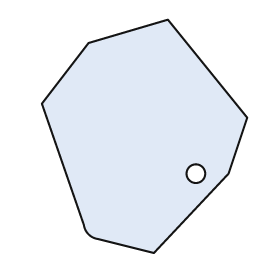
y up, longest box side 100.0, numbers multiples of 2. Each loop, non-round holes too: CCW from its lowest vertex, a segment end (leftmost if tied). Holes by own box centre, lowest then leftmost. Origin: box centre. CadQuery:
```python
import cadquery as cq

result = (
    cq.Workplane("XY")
    .moveTo(4.0, -50.0)
    .lineTo(36.0, -16.0)
    .lineTo(44.0, 8.0)
    .lineTo(10.0, 50.0)
    .lineTo(-24.0, 40.0)
    .lineTo(-44.0, 14.0)
    .lineTo(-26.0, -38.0)
    .threePointArc((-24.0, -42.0), (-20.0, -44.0))
    .close()
    .moveTo(22.0, -16.0)
    .circle(4.0)
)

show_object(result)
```